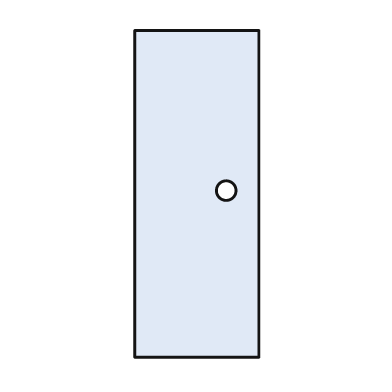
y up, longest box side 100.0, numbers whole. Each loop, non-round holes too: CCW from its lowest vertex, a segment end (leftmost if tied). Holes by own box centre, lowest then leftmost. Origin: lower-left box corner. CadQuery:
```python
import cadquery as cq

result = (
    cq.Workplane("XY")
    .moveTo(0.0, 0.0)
    .lineTo(38.0, 0.0)
    .lineTo(38.0, 100.0)
    .lineTo(0.0, 100.0)
    .close()
    .moveTo(28.0, 51.0)
    .circle(3.0)
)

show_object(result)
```